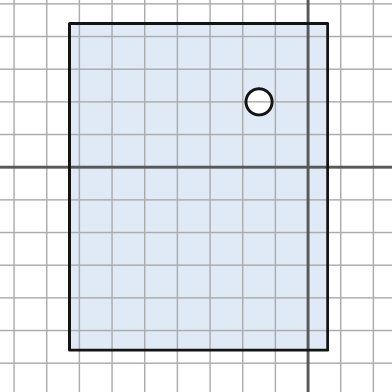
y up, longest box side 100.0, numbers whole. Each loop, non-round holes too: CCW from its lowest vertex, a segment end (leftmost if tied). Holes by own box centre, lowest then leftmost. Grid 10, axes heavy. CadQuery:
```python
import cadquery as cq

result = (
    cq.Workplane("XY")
    .moveTo(-73.0, -56.0)
    .lineTo(6.0, -56.0)
    .lineTo(6.0, 44.0)
    .lineTo(-73.0, 44.0)
    .close()
    .moveTo(-15.0, 20.0)
    .circle(4.0)
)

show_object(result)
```